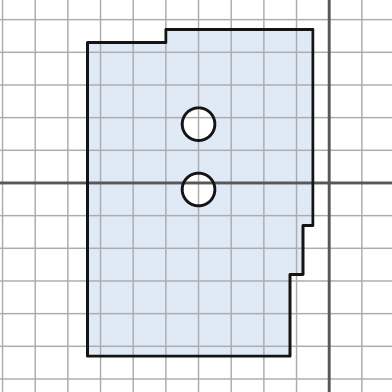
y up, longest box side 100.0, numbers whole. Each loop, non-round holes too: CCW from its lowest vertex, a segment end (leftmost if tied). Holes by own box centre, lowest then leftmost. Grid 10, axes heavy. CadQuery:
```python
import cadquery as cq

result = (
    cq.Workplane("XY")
    .moveTo(-74.0, -53.0)
    .lineTo(-12.0, -53.0)
    .lineTo(-12.0, -28.0)
    .lineTo(-8.0, -28.0)
    .lineTo(-8.0, -13.0)
    .lineTo(-5.0, -13.0)
    .lineTo(-5.0, 47.0)
    .lineTo(-50.0, 47.0)
    .lineTo(-50.0, 43.0)
    .lineTo(-74.0, 43.0)
    .close()
    .moveTo(-40.0, -2.0)
    .circle(5.0)
    .moveTo(-40.0, 18.0)
    .circle(5.0)
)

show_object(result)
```